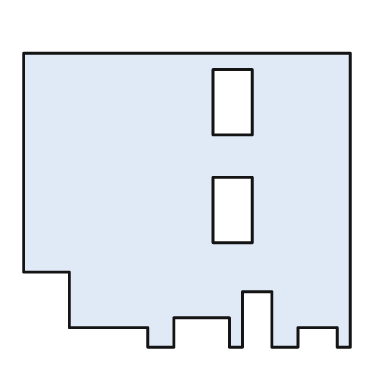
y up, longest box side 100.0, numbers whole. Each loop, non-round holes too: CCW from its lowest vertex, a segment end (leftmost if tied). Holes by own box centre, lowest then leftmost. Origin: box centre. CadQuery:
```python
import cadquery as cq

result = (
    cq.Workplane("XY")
    .moveTo(-12.0, -45.0)
    .lineTo(-4.0, -45.0)
    .lineTo(-4.0, -36.0)
    .lineTo(13.0, -36.0)
    .lineTo(13.0, -45.0)
    .lineTo(17.0, -45.0)
    .lineTo(17.0, -28.0)
    .lineTo(26.0, -28.0)
    .lineTo(26.0, -45.0)
    .lineTo(34.0, -45.0)
    .lineTo(34.0, -39.0)
    .lineTo(46.0, -39.0)
    .lineTo(46.0, -45.0)
    .lineTo(50.0, -45.0)
    .lineTo(50.0, 45.0)
    .lineTo(-50.0, 45.0)
    .lineTo(-50.0, -22.0)
    .lineTo(-36.0, -22.0)
    .lineTo(-36.0, -39.0)
    .lineTo(-12.0, -39.0)
    .close()
    .moveTo(8.0, -13.0)
    .lineTo(20.0, -13.0)
    .lineTo(20.0, 7.0)
    .lineTo(8.0, 7.0)
    .close()
    .moveTo(8.0, 20.0)
    .lineTo(20.0, 20.0)
    .lineTo(20.0, 40.0)
    .lineTo(8.0, 40.0)
    .close()
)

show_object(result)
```